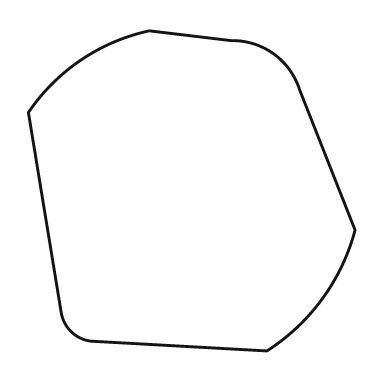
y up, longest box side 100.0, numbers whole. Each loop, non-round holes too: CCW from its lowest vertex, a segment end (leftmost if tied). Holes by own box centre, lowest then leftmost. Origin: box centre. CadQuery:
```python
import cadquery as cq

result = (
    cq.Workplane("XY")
    .moveTo(23.0, -49.0)
    .threePointArc((40.0, -33.0), (50.0, -12.0))
    .lineTo(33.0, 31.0)
    .threePointArc((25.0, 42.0), (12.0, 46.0))
    .lineTo(-13.0, 49.0)
    .threePointArc((-34.0, 40.0), (-50.0, 24.0))
    .lineTo(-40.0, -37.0)
    .threePointArc((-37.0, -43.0), (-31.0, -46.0))
    .close()
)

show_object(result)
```